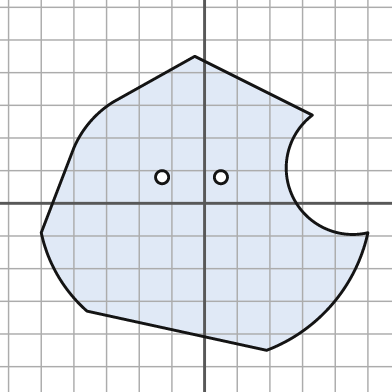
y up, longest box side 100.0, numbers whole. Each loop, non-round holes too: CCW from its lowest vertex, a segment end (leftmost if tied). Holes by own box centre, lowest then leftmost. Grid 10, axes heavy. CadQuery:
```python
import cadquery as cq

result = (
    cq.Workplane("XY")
    .moveTo(19.0, -45.0)
    .threePointArc((39.0, -31.0), (50.0, -9.0))
    .threePointArc((27.0, 2.0), (33.0, 27.0))
    .lineTo(-3.0, 45.0)
    .lineTo(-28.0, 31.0)
    .threePointArc((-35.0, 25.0), (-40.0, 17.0))
    .lineTo(-50.0, -9.0)
    .threePointArc((-45.0, -22.0), (-36.0, -33.0))
    .close()
    .moveTo(-13.0, 8.0)
    .circle(2.0)
    .moveTo(5.0, 8.0)
    .circle(2.0)
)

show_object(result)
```